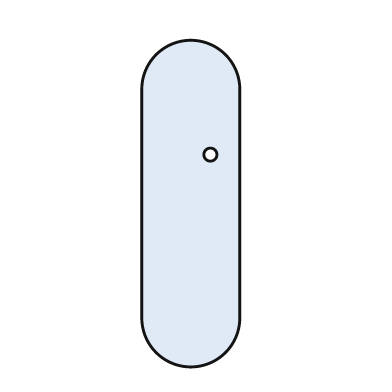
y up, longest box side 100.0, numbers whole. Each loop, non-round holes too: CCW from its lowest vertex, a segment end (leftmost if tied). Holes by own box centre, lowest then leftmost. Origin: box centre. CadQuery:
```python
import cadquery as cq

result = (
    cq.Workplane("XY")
    .moveTo(-15.0, -35.0)
    .threePointArc((0.0, -50.0), (15.0, -35.0))
    .lineTo(15.0, 35.0)
    .threePointArc((0.0, 50.0), (-15.0, 35.0))
    .close()
    .moveTo(6.0, 15.0)
    .circle(2.0)
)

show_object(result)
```